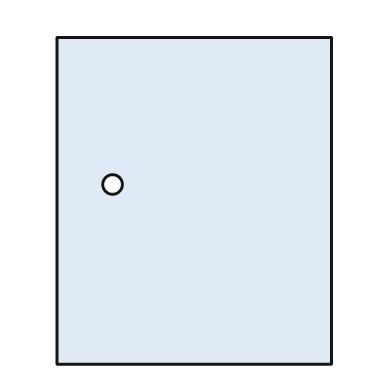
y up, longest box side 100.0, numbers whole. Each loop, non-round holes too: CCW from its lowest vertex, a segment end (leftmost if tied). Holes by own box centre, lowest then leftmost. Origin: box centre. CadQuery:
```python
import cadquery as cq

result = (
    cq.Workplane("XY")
    .moveTo(-42.0, -50.0)
    .lineTo(42.0, -50.0)
    .lineTo(42.0, 50.0)
    .lineTo(-42.0, 50.0)
    .close()
    .moveTo(-25.0, 5.0)
    .circle(3.0)
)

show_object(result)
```